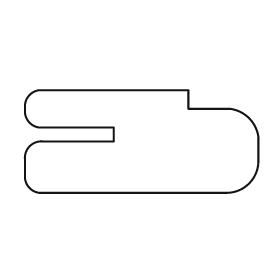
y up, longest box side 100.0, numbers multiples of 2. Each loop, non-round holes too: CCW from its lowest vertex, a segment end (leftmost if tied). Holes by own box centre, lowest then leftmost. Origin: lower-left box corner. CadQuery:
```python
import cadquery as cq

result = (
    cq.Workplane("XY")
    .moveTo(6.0, 0.0)
    .lineTo(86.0, 0.0)
    .threePointArc((96.0, 4.0), (100.0, 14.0))
    .lineTo(100.0, 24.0)
    .threePointArc((96.0, 32.0), (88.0, 36.0))
    .lineTo(70.0, 36.0)
    .lineTo(70.0, 44.0)
    .lineTo(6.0, 44.0)
    .threePointArc((2.0, 42.0), (0.0, 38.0))
    .lineTo(0.0, 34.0)
    .threePointArc((2.0, 30.0), (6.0, 28.0))
    .lineTo(38.0, 28.0)
    .lineTo(38.0, 22.0)
    .lineTo(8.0, 22.0)
    .threePointArc((2.0, 20.0), (0.0, 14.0))
    .lineTo(0.0, 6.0)
    .threePointArc((2.0, 2.0), (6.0, 0.0))
    .close()
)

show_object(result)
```